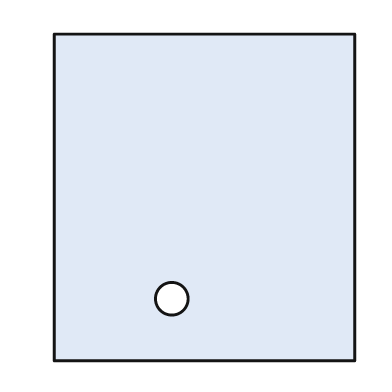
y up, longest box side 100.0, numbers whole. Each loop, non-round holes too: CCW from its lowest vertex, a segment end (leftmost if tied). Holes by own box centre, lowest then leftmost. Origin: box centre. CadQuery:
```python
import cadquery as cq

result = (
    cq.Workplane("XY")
    .moveTo(-46.0, -50.0)
    .lineTo(46.0, -50.0)
    .lineTo(46.0, 50.0)
    .lineTo(-46.0, 50.0)
    .close()
    .moveTo(-10.0, -31.0)
    .circle(5.0)
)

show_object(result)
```